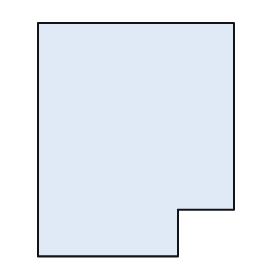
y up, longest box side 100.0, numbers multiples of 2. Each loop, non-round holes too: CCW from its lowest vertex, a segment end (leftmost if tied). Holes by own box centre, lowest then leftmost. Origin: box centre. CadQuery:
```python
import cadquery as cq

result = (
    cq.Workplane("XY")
    .moveTo(-42.0, -50.0)
    .lineTo(18.0, -50.0)
    .lineTo(18.0, -30.0)
    .lineTo(42.0, -30.0)
    .lineTo(42.0, 50.0)
    .lineTo(-42.0, 50.0)
    .close()
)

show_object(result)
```